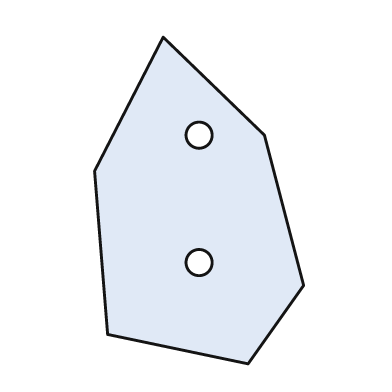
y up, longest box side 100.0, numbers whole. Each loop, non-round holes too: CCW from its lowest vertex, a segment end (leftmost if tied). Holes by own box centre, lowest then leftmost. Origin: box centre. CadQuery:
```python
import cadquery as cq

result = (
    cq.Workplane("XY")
    .moveTo(15.0, -50.0)
    .lineTo(32.0, -26.0)
    .lineTo(20.0, 20.0)
    .lineTo(-11.0, 50.0)
    .lineTo(-32.0, 9.0)
    .lineTo(-28.0, -41.0)
    .close()
    .moveTo(0.0, -19.0)
    .circle(4.0)
    .moveTo(0.0, 20.0)
    .circle(4.0)
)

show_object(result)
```